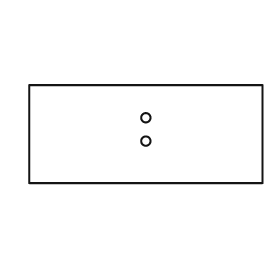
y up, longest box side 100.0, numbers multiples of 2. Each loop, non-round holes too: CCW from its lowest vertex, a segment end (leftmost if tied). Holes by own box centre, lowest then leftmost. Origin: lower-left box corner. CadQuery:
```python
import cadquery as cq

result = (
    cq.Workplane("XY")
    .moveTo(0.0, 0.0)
    .lineTo(100.0, 0.0)
    .lineTo(100.0, 42.0)
    .lineTo(0.0, 42.0)
    .close()
    .moveTo(50.0, 18.0)
    .circle(2.0)
    .moveTo(50.0, 28.0)
    .circle(2.0)
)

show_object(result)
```